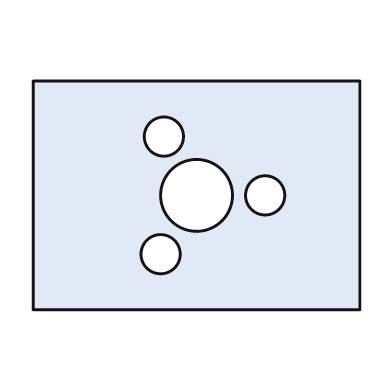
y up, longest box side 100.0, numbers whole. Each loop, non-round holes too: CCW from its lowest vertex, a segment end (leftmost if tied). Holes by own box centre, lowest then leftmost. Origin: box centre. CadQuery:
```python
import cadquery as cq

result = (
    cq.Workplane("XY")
    .moveTo(-50.0, -35.0)
    .lineTo(50.0, -35.0)
    .lineTo(50.0, 35.0)
    .lineTo(-50.0, 35.0)
    .close()
    .moveTo(-11.0, -18.0)
    .circle(6.0)
    .moveTo(0.0, 0.0)
    .circle(11.0)
    .moveTo(21.0, 0.0)
    .circle(6.0)
    .moveTo(-10.0, 18.0)
    .circle(6.0)
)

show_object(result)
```